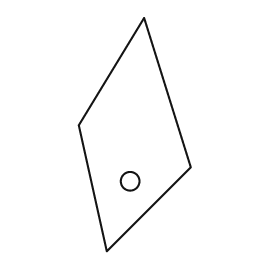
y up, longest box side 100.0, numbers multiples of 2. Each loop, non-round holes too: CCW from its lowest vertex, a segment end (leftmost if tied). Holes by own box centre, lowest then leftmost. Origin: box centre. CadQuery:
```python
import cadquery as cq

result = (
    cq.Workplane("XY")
    .moveTo(-12.0, -50.0)
    .lineTo(24.0, -14.0)
    .lineTo(4.0, 50.0)
    .lineTo(-24.0, 4.0)
    .close()
    .moveTo(-2.0, -20.0)
    .circle(4.0)
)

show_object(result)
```